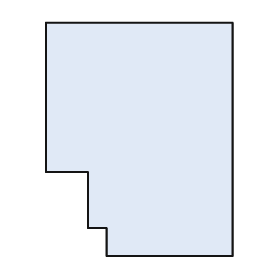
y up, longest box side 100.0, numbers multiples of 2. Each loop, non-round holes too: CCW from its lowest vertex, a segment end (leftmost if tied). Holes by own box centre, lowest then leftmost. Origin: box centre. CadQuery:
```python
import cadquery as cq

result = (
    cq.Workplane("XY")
    .moveTo(-14.0, -50.0)
    .lineTo(40.0, -50.0)
    .lineTo(40.0, 50.0)
    .lineTo(-40.0, 50.0)
    .lineTo(-40.0, -14.0)
    .lineTo(-22.0, -14.0)
    .lineTo(-22.0, -38.0)
    .lineTo(-14.0, -38.0)
    .close()
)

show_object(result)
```